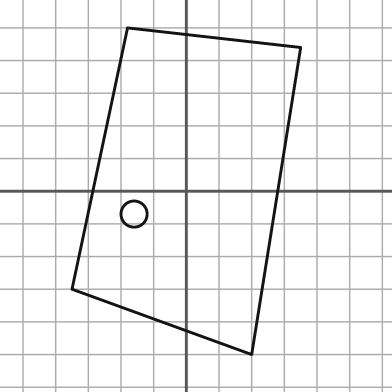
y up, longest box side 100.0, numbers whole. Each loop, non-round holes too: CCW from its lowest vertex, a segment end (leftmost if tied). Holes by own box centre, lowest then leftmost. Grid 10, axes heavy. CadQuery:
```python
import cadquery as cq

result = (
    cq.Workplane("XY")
    .moveTo(20.0, -50.0)
    .lineTo(35.0, 44.0)
    .lineTo(-18.0, 50.0)
    .lineTo(-35.0, -30.0)
    .close()
    .moveTo(-16.0, -7.0)
    .circle(4.0)
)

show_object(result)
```